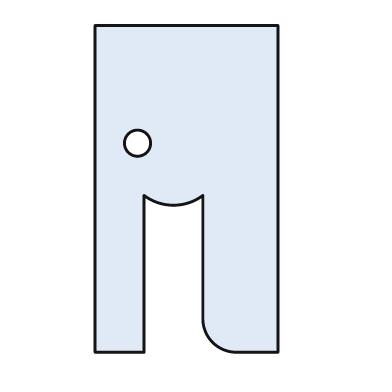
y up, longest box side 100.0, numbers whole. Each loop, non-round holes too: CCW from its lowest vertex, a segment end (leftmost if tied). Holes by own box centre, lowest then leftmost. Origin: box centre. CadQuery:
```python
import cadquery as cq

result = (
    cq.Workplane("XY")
    .moveTo(-28.0, -50.0)
    .lineTo(-13.0, -50.0)
    .lineTo(-13.0, -2.0)
    .threePointArc((-4.0, -5.0), (5.0, -2.0))
    .lineTo(5.0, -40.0)
    .threePointArc((8.0, -47.0), (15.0, -50.0))
    .lineTo(28.0, -50.0)
    .lineTo(28.0, 50.0)
    .lineTo(-28.0, 50.0)
    .close()
    .moveTo(-15.0, 14.0)
    .circle(4.0)
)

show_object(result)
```